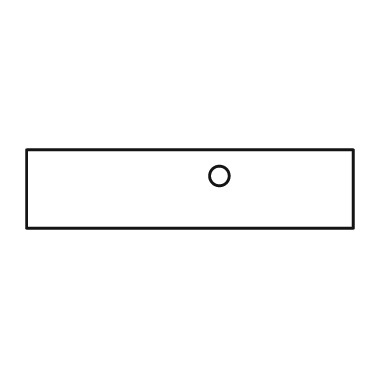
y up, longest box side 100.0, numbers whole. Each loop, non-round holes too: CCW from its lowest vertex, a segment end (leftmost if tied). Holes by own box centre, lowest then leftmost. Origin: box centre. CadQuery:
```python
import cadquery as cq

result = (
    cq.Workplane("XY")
    .moveTo(-50.0, -12.0)
    .lineTo(50.0, -12.0)
    .lineTo(50.0, 12.0)
    .lineTo(-50.0, 12.0)
    .close()
    .moveTo(9.0, 4.0)
    .circle(3.0)
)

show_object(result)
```